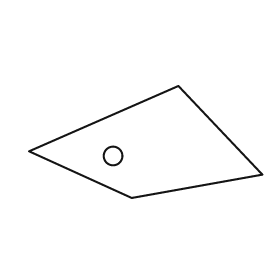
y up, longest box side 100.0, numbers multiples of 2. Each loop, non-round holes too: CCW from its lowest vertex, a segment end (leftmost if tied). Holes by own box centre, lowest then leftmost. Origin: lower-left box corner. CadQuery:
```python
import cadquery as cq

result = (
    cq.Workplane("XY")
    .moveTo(44.0, 0.0)
    .lineTo(100.0, 10.0)
    .lineTo(64.0, 48.0)
    .lineTo(0.0, 20.0)
    .close()
    .moveTo(36.0, 18.0)
    .circle(4.0)
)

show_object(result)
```